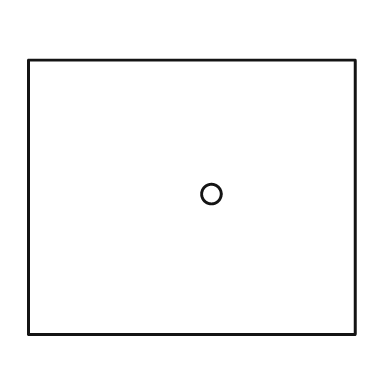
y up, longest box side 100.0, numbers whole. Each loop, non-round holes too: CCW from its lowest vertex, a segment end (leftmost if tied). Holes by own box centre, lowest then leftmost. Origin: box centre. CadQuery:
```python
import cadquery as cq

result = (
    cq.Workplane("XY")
    .moveTo(-50.0, -42.0)
    .lineTo(50.0, -42.0)
    .lineTo(50.0, 42.0)
    .lineTo(-50.0, 42.0)
    .close()
    .moveTo(6.0, 1.0)
    .circle(3.0)
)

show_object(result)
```